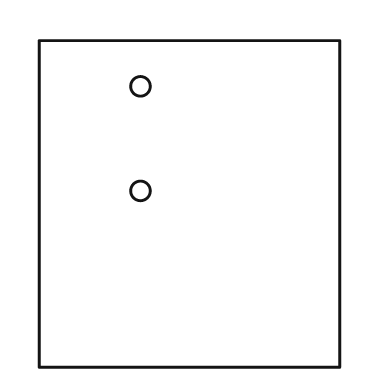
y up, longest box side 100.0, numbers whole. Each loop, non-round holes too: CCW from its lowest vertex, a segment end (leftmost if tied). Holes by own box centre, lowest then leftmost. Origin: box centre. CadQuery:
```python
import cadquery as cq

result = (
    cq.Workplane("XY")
    .moveTo(-46.0, -50.0)
    .lineTo(46.0, -50.0)
    .lineTo(46.0, 50.0)
    .lineTo(-46.0, 50.0)
    .close()
    .moveTo(-15.0, 4.0)
    .circle(3.0)
    .moveTo(-15.0, 36.0)
    .circle(3.0)
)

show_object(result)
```